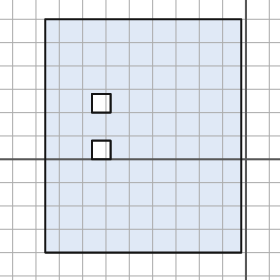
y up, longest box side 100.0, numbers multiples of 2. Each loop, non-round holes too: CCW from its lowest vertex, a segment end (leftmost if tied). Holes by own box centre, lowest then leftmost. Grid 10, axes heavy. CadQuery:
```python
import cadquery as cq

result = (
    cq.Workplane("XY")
    .moveTo(-86.0, -40.0)
    .lineTo(-2.0, -40.0)
    .lineTo(-2.0, 60.0)
    .lineTo(-86.0, 60.0)
    .close()
    .moveTo(-66.0, 0.0)
    .lineTo(-58.0, 0.0)
    .lineTo(-58.0, 8.0)
    .lineTo(-66.0, 8.0)
    .close()
    .moveTo(-66.0, 20.0)
    .lineTo(-58.0, 20.0)
    .lineTo(-58.0, 28.0)
    .lineTo(-66.0, 28.0)
    .close()
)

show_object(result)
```